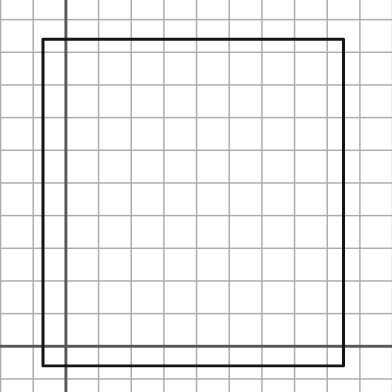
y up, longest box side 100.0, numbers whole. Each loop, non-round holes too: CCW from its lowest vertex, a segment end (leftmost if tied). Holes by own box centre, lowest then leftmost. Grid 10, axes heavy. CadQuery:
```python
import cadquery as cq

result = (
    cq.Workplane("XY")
    .moveTo(-7.0, -6.0)
    .lineTo(85.0, -6.0)
    .lineTo(85.0, 94.0)
    .lineTo(-7.0, 94.0)
    .close()
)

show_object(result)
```